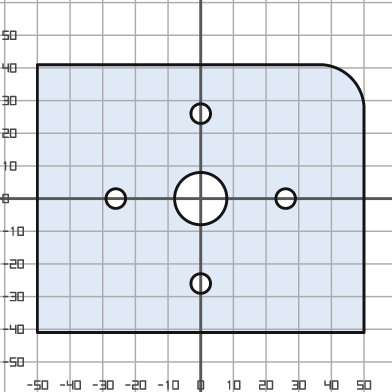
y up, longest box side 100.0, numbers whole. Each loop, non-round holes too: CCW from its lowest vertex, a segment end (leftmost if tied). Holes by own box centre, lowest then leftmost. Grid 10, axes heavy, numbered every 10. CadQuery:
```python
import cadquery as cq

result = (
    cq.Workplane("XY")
    .moveTo(-50.0, -41.0)
    .lineTo(50.0, -41.0)
    .lineTo(50.0, 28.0)
    .threePointArc((46.0, 37.0), (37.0, 41.0))
    .lineTo(-50.0, 41.0)
    .close()
    .moveTo(0.0, -26.0)
    .circle(3.0)
    .moveTo(-26.0, 0.0)
    .circle(3.0)
    .moveTo(0.0, 0.0)
    .circle(8.0)
    .moveTo(26.0, 0.0)
    .circle(3.0)
    .moveTo(0.0, 26.0)
    .circle(3.0)
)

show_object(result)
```